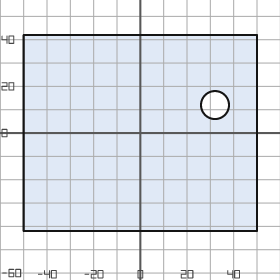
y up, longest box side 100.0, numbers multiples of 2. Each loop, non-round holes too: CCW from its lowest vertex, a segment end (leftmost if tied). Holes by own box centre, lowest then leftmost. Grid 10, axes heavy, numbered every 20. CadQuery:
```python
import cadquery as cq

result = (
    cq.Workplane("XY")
    .moveTo(-50.0, -42.0)
    .lineTo(50.0, -42.0)
    .lineTo(50.0, 42.0)
    .lineTo(-50.0, 42.0)
    .close()
    .moveTo(32.0, 12.0)
    .circle(6.0)
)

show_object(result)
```